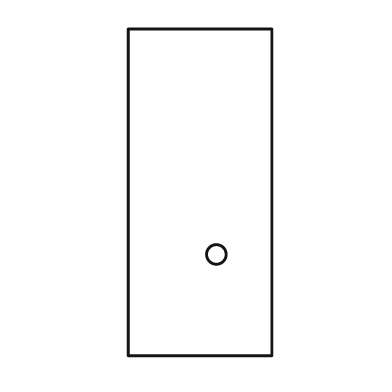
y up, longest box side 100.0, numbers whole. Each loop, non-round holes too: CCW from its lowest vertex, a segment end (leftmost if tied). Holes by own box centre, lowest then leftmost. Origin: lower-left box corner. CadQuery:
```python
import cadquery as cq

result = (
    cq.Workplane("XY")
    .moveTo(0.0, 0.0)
    .lineTo(44.0, 0.0)
    .lineTo(44.0, 100.0)
    .lineTo(0.0, 100.0)
    .close()
    .moveTo(27.0, 31.0)
    .circle(3.0)
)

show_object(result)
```